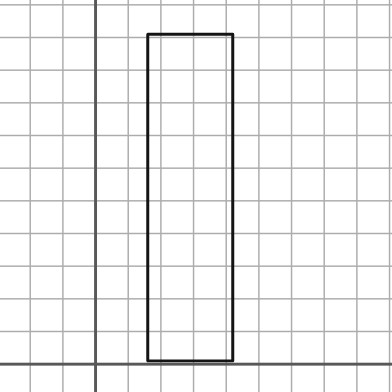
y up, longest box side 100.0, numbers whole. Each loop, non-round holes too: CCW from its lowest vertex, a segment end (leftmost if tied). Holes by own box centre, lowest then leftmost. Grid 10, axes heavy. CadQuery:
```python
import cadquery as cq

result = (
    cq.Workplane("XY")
    .moveTo(16.0, 1.0)
    .lineTo(42.0, 1.0)
    .lineTo(42.0, 101.0)
    .lineTo(16.0, 101.0)
    .close()
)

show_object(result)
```